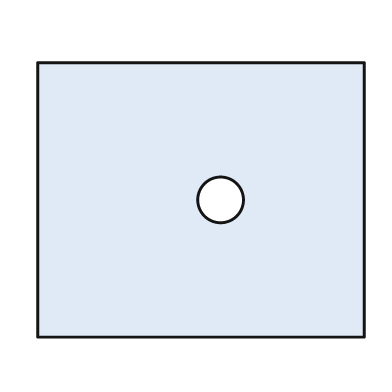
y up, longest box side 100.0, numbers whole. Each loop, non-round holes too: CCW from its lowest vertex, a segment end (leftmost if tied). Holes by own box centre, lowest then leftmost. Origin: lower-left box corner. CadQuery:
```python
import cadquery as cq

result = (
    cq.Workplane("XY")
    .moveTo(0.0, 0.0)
    .lineTo(100.0, 0.0)
    .lineTo(100.0, 84.0)
    .lineTo(0.0, 84.0)
    .close()
    .moveTo(56.0, 42.0)
    .circle(7.0)
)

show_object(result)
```